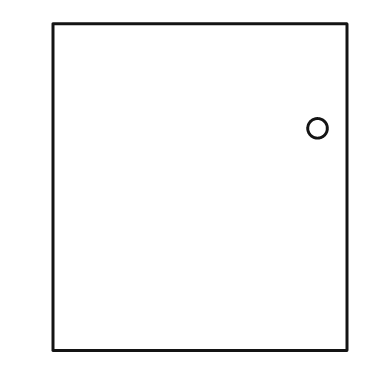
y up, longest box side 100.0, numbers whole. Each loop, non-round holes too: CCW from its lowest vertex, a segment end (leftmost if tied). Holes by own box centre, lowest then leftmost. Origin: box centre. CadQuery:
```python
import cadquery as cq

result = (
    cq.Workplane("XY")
    .moveTo(-45.0, -50.0)
    .lineTo(45.0, -50.0)
    .lineTo(45.0, 50.0)
    .lineTo(-45.0, 50.0)
    .close()
    .moveTo(36.0, 18.0)
    .circle(3.0)
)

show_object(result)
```